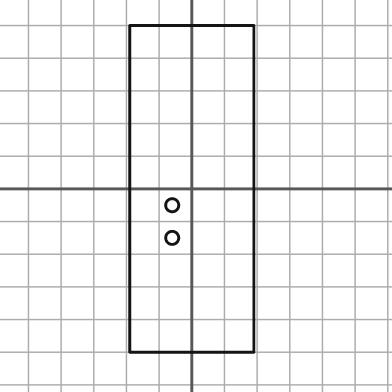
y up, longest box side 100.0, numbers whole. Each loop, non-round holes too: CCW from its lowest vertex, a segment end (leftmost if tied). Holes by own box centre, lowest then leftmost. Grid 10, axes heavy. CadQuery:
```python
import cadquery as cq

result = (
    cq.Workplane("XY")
    .moveTo(-19.0, -50.0)
    .lineTo(19.0, -50.0)
    .lineTo(19.0, 50.0)
    .lineTo(-19.0, 50.0)
    .close()
    .moveTo(-6.0, -15.0)
    .circle(2.0)
    .moveTo(-6.0, -5.0)
    .circle(2.0)
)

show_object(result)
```